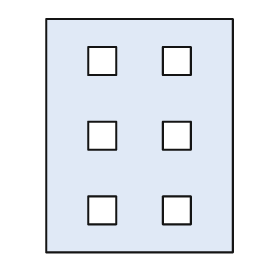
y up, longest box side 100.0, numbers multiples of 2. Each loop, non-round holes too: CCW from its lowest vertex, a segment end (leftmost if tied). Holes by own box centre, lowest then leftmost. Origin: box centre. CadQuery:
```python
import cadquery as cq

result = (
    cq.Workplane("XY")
    .moveTo(-40.0, -50.0)
    .lineTo(40.0, -50.0)
    .lineTo(40.0, 50.0)
    .lineTo(-40.0, 50.0)
    .close()
    .moveTo(-22.0, -38.0)
    .lineTo(-10.0, -38.0)
    .lineTo(-10.0, -26.0)
    .lineTo(-22.0, -26.0)
    .close()
    .moveTo(10.0, -38.0)
    .lineTo(22.0, -38.0)
    .lineTo(22.0, -26.0)
    .lineTo(10.0, -26.0)
    .close()
    .moveTo(-22.0, -6.0)
    .lineTo(-10.0, -6.0)
    .lineTo(-10.0, 6.0)
    .lineTo(-22.0, 6.0)
    .close()
    .moveTo(10.0, -6.0)
    .lineTo(22.0, -6.0)
    .lineTo(22.0, 6.0)
    .lineTo(10.0, 6.0)
    .close()
    .moveTo(-22.0, 26.0)
    .lineTo(-10.0, 26.0)
    .lineTo(-10.0, 38.0)
    .lineTo(-22.0, 38.0)
    .close()
    .moveTo(10.0, 26.0)
    .lineTo(22.0, 26.0)
    .lineTo(22.0, 38.0)
    .lineTo(10.0, 38.0)
    .close()
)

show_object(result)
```